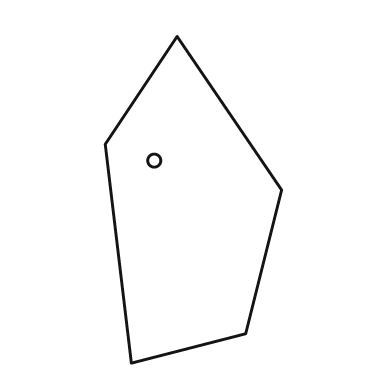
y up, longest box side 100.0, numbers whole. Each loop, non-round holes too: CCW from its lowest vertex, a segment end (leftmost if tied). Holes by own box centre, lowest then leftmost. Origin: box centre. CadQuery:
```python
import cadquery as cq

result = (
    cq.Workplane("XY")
    .moveTo(-19.0, -50.0)
    .lineTo(16.0, -41.0)
    .lineTo(27.0, 3.0)
    .lineTo(-5.0, 50.0)
    .lineTo(-27.0, 17.0)
    .close()
    .moveTo(-12.0, 12.0)
    .circle(2.0)
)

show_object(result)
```